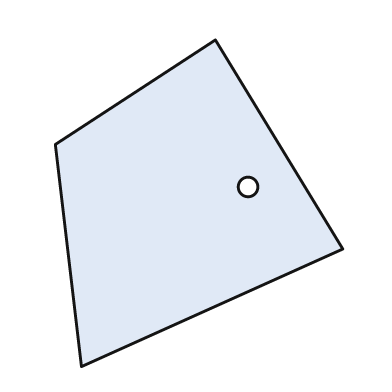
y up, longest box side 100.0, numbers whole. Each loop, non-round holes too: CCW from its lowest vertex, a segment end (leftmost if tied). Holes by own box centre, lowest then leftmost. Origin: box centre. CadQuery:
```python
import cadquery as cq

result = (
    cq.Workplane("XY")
    .moveTo(-36.0, -50.0)
    .lineTo(44.0, -14.0)
    .lineTo(5.0, 50.0)
    .lineTo(-44.0, 18.0)
    .close()
    .moveTo(15.0, 5.0)
    .circle(3.0)
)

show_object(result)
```